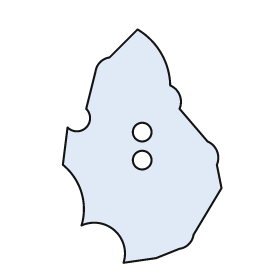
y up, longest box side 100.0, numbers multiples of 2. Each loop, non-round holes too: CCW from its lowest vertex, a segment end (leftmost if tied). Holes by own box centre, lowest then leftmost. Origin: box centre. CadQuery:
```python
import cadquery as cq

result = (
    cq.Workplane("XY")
    .moveTo(-8.0, -50.0)
    .lineTo(6.0, -48.0)
    .lineTo(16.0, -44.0)
    .threePointArc((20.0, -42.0), (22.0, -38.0))
    .lineTo(34.0, -18.0)
    .lineTo(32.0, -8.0)
    .threePointArc((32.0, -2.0), (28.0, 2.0))
    .lineTo(16.0, 16.0)
    .threePointArc((16.0, 22.0), (12.0, 26.0))
    .threePointArc((8.0, 40.0), (-2.0, 50.0))
    .lineTo(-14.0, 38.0)
    .threePointArc((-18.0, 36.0), (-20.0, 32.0))
    .lineTo(-24.0, 16.0)
    .threePointArc((-24.0, 8.0), (-32.0, 8.0))
    .lineTo(-34.0, -8.0)
    .threePointArc((-26.0, -20.0), (-26.0, -34.0))
    .threePointArc((-12.0, -36.0), (-8.0, -50.0))
    .close()
    .moveTo(0.0, -6.0)
    .circle(4.0)
    .moveTo(0.0, 6.0)
    .circle(4.0)
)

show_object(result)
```